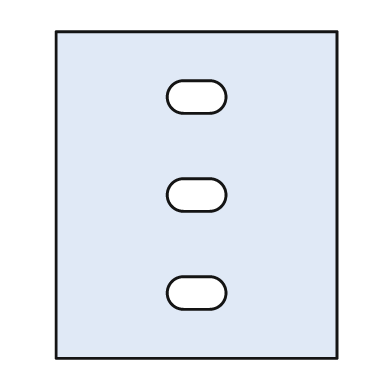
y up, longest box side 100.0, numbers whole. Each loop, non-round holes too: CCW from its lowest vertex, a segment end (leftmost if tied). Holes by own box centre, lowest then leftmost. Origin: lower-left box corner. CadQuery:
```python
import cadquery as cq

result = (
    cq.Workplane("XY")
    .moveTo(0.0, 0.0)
    .lineTo(86.0, 0.0)
    .lineTo(86.0, 100.0)
    .lineTo(0.0, 100.0)
    .close()
    .moveTo(39.0, 15.0)
    .lineTo(47.0, 15.0)
    .threePointArc((52.0, 20.0), (47.0, 25.0))
    .lineTo(39.0, 25.0)
    .threePointArc((34.0, 20.0), (39.0, 15.0))
    .close()
    .moveTo(39.0, 45.0)
    .lineTo(47.0, 45.0)
    .threePointArc((52.0, 50.0), (47.0, 55.0))
    .lineTo(39.0, 55.0)
    .threePointArc((34.0, 50.0), (39.0, 45.0))
    .close()
    .moveTo(39.0, 75.0)
    .lineTo(47.0, 75.0)
    .threePointArc((52.0, 80.0), (47.0, 85.0))
    .lineTo(39.0, 85.0)
    .threePointArc((34.0, 80.0), (39.0, 75.0))
    .close()
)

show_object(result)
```